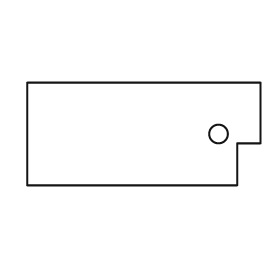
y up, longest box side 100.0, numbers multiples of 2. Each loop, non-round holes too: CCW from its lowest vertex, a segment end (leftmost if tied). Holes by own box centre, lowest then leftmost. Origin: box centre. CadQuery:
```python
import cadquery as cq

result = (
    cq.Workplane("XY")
    .moveTo(-50.0, -22.0)
    .lineTo(40.0, -22.0)
    .lineTo(40.0, -4.0)
    .lineTo(50.0, -4.0)
    .lineTo(50.0, 22.0)
    .lineTo(-50.0, 22.0)
    .close()
    .moveTo(32.0, 0.0)
    .circle(4.0)
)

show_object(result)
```